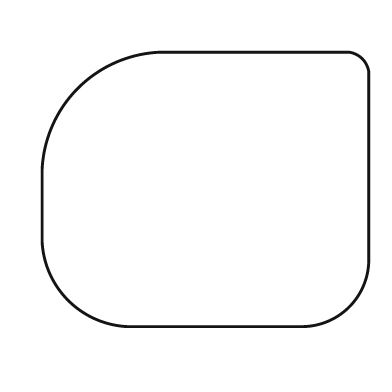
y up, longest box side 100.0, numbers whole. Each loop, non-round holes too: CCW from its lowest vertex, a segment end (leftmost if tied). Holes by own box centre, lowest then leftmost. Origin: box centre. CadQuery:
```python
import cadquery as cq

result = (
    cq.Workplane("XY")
    .moveTo(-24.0, -42.0)
    .lineTo(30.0, -42.0)
    .threePointArc((44.0, -36.0), (50.0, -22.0))
    .lineTo(50.0, 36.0)
    .threePointArc((48.0, 40.0), (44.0, 42.0))
    .lineTo(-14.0, 42.0)
    .threePointArc((-39.0, 31.0), (-50.0, 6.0))
    .lineTo(-50.0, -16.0)
    .threePointArc((-42.0, -34.0), (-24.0, -42.0))
    .close()
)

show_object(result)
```